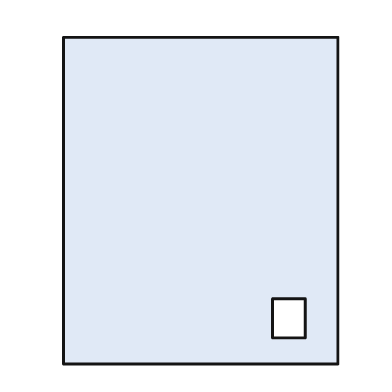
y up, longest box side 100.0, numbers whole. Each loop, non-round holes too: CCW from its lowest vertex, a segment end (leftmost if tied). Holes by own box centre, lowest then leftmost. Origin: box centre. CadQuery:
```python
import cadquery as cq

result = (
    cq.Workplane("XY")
    .moveTo(-42.0, -50.0)
    .lineTo(42.0, -50.0)
    .lineTo(42.0, 50.0)
    .lineTo(-42.0, 50.0)
    .close()
    .moveTo(22.0, -42.0)
    .lineTo(32.0, -42.0)
    .lineTo(32.0, -30.0)
    .lineTo(22.0, -30.0)
    .close()
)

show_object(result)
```